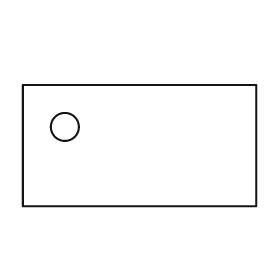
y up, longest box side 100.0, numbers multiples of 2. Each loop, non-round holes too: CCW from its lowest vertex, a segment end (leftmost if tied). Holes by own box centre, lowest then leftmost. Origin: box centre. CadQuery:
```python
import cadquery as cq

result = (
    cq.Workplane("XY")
    .moveTo(-50.0, -26.0)
    .lineTo(50.0, -26.0)
    .lineTo(50.0, 26.0)
    .lineTo(-50.0, 26.0)
    .close()
    .moveTo(-32.0, 8.0)
    .circle(6.0)
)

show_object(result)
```